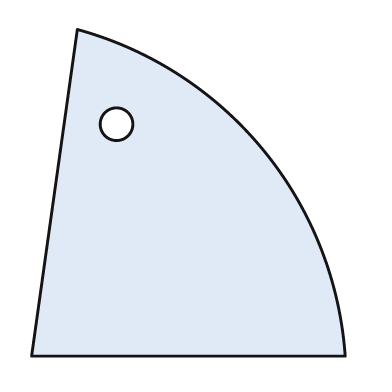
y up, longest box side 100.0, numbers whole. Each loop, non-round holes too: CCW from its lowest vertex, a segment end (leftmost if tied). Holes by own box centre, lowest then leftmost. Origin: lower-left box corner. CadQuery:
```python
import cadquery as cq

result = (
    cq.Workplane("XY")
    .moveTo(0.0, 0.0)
    .lineTo(96.0, 0.0)
    .threePointArc((71.0, 63.0), (14.0, 100.0))
    .close()
    .moveTo(26.0, 71.0)
    .circle(5.0)
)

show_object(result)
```